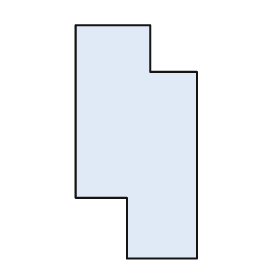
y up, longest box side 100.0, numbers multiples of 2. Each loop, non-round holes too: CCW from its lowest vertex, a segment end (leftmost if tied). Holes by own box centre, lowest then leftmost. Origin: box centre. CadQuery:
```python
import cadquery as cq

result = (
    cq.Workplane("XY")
    .moveTo(-4.0, -50.0)
    .lineTo(26.0, -50.0)
    .lineTo(26.0, 30.0)
    .lineTo(6.0, 30.0)
    .lineTo(6.0, 50.0)
    .lineTo(-26.0, 50.0)
    .lineTo(-26.0, -24.0)
    .lineTo(-4.0, -24.0)
    .close()
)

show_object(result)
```